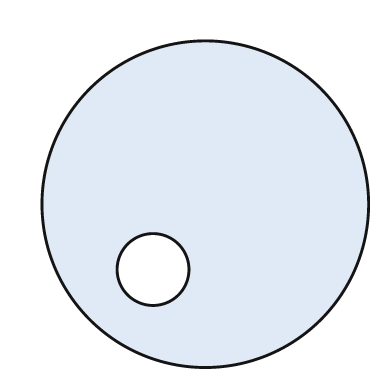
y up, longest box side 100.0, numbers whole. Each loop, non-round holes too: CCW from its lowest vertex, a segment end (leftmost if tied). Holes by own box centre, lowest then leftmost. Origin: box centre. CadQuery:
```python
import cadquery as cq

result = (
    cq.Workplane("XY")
    .moveTo(0.0, 0.0)
    .circle(50.0)
    .moveTo(-16.0, -20.0)
    .circle(11.0)
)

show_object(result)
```